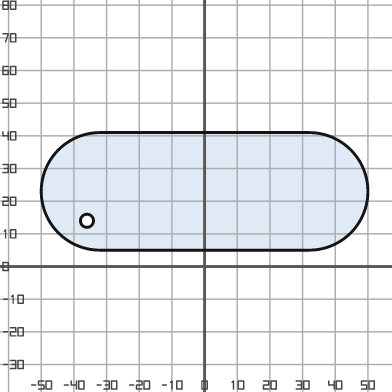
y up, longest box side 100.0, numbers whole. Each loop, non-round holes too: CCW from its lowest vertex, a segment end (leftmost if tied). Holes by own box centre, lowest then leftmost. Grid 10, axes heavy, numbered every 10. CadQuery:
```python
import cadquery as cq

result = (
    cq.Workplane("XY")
    .moveTo(-32.0, 5.0)
    .lineTo(32.0, 5.0)
    .threePointArc((50.0, 23.0), (32.0, 41.0))
    .lineTo(-32.0, 41.0)
    .threePointArc((-50.0, 23.0), (-32.0, 5.0))
    .close()
    .moveTo(-36.0, 14.0)
    .circle(2.0)
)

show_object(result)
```